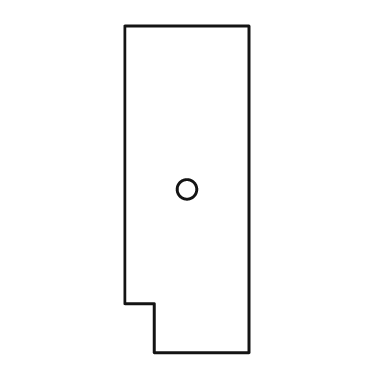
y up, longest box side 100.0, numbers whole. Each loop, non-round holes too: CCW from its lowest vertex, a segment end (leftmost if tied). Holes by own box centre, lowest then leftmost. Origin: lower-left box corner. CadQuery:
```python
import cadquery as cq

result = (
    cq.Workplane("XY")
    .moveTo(9.0, 0.0)
    .lineTo(38.0, 0.0)
    .lineTo(38.0, 100.0)
    .lineTo(0.0, 100.0)
    .lineTo(0.0, 15.0)
    .lineTo(9.0, 15.0)
    .close()
    .moveTo(19.0, 50.0)
    .circle(3.0)
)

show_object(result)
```